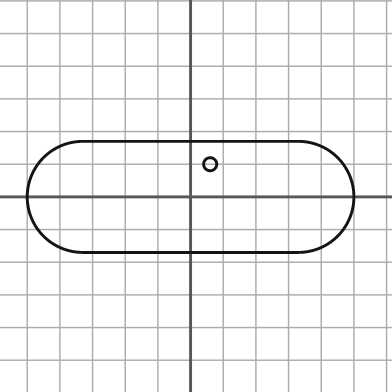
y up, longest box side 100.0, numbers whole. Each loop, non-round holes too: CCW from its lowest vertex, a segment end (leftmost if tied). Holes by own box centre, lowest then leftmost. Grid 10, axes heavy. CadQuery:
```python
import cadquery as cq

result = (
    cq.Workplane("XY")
    .moveTo(-33.0, -17.0)
    .lineTo(33.0, -17.0)
    .threePointArc((50.0, 0.0), (33.0, 17.0))
    .lineTo(-33.0, 17.0)
    .threePointArc((-50.0, 0.0), (-33.0, -17.0))
    .close()
    .moveTo(6.0, 10.0)
    .circle(2.0)
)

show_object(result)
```